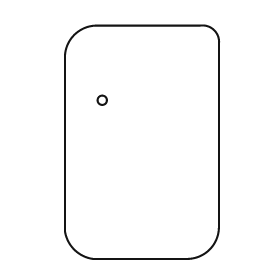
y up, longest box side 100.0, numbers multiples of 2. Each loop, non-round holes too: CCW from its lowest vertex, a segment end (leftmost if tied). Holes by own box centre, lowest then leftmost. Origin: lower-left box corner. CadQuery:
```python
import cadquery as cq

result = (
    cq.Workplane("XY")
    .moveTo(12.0, 0.0)
    .lineTo(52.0, 0.0)
    .threePointArc((62.0, 4.0), (66.0, 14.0))
    .lineTo(66.0, 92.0)
    .threePointArc((64.0, 98.0), (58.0, 100.0))
    .lineTo(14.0, 100.0)
    .threePointArc((4.0, 96.0), (0.0, 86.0))
    .lineTo(0.0, 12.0)
    .threePointArc((4.0, 4.0), (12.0, 0.0))
    .close()
    .moveTo(16.0, 68.0)
    .circle(2.0)
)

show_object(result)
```